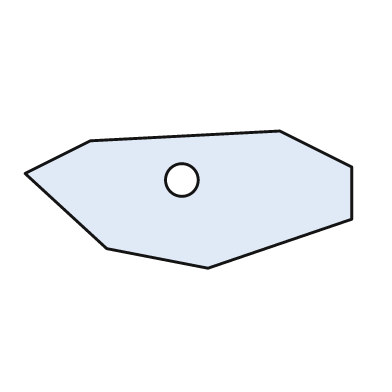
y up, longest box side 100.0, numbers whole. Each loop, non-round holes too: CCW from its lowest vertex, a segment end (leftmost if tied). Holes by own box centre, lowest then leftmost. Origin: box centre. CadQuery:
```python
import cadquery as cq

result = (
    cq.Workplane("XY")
    .moveTo(6.0, -21.0)
    .lineTo(50.0, -6.0)
    .lineTo(50.0, 10.0)
    .lineTo(28.0, 21.0)
    .lineTo(-30.0, 18.0)
    .lineTo(-50.0, 8.0)
    .lineTo(-25.0, -15.0)
    .close()
    .moveTo(-2.0, 6.0)
    .circle(5.0)
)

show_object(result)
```